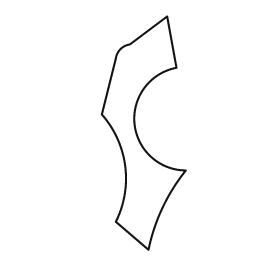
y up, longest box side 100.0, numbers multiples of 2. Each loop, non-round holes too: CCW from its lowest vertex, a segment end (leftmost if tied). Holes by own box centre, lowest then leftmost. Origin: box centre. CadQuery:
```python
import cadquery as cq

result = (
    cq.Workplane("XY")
    .moveTo(2.0, -50.0)
    .threePointArc((8.0, -32.0), (18.0, -16.0))
    .threePointArc((-4.0, 4.0), (14.0, 28.0))
    .lineTo(10.0, 50.0)
    .lineTo(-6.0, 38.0)
    .threePointArc((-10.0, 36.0), (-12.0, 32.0))
    .lineTo(-18.0, 8.0)
    .threePointArc((-8.0, -14.0), (-12.0, -38.0))
    .close()
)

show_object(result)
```